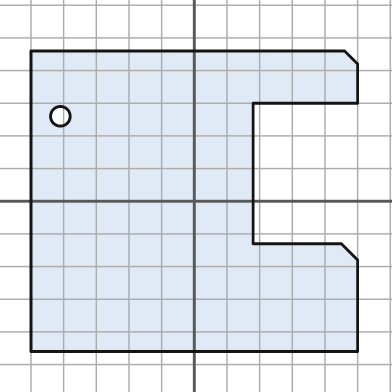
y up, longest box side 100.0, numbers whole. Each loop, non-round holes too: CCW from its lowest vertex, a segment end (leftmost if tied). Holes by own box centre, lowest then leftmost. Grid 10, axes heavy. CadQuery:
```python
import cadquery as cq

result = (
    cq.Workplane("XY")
    .moveTo(-50.0, -46.0)
    .lineTo(50.0, -46.0)
    .lineTo(50.0, -18.0)
    .lineTo(45.0, -13.0)
    .lineTo(18.0, -13.0)
    .lineTo(18.0, 30.0)
    .lineTo(50.0, 30.0)
    .lineTo(50.0, 42.0)
    .lineTo(46.0, 46.0)
    .lineTo(-50.0, 46.0)
    .close()
    .moveTo(-41.0, 26.0)
    .circle(3.0)
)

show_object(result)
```